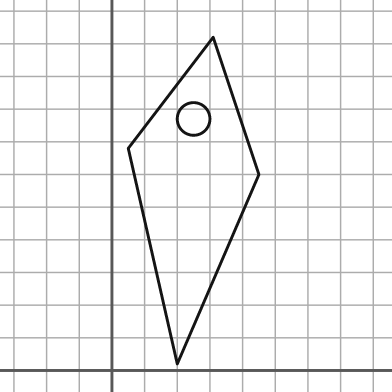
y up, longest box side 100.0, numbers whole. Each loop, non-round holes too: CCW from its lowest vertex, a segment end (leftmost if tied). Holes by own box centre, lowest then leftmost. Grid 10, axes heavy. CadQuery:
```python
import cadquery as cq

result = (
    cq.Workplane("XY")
    .moveTo(20.0, 2.0)
    .lineTo(45.0, 60.0)
    .lineTo(31.0, 102.0)
    .lineTo(5.0, 68.0)
    .close()
    .moveTo(25.0, 77.0)
    .circle(5.0)
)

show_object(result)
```